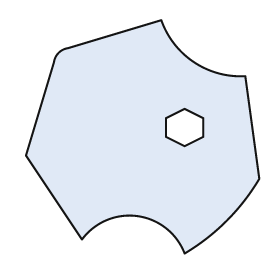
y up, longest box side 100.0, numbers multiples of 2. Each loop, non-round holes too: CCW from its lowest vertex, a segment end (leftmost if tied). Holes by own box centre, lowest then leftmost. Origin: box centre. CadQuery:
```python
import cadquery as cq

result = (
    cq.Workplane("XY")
    .moveTo(18.0, -50.0)
    .threePointArc((36.0, -36.0), (50.0, -18.0))
    .lineTo(44.0, 26.0)
    .threePointArc((22.0, 32.0), (8.0, 50.0))
    .lineTo(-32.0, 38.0)
    .threePointArc((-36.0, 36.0), (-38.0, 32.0))
    .lineTo(-50.0, -8.0)
    .lineTo(-26.0, -44.0)
    .threePointArc((-2.0, -34.0), (18.0, -50.0))
    .close()
    .moveTo(18.0, -4.0)
    .lineTo(26.0, 0.0)
    .lineTo(26.0, 8.0)
    .lineTo(18.0, 12.0)
    .lineTo(10.0, 8.0)
    .lineTo(10.0, 0.0)
    .close()
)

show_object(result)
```